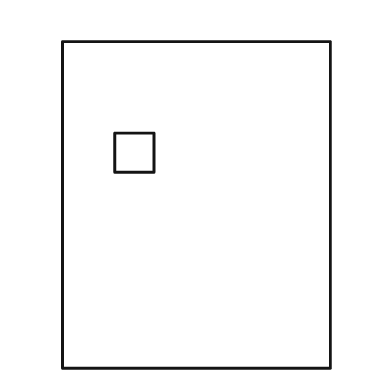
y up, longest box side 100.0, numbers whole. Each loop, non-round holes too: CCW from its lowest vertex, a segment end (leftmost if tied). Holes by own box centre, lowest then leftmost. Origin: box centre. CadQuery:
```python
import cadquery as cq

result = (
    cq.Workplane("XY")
    .moveTo(-41.0, -50.0)
    .lineTo(41.0, -50.0)
    .lineTo(41.0, 50.0)
    .lineTo(-41.0, 50.0)
    .close()
    .moveTo(-25.0, 10.0)
    .lineTo(-13.0, 10.0)
    .lineTo(-13.0, 22.0)
    .lineTo(-25.0, 22.0)
    .close()
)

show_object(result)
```